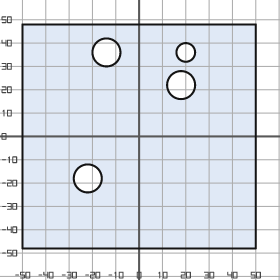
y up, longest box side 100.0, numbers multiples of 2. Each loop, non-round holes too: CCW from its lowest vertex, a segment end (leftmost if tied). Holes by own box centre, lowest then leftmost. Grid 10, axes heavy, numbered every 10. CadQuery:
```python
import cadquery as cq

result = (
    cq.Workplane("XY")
    .moveTo(-50.0, -48.0)
    .lineTo(50.0, -48.0)
    .lineTo(50.0, 48.0)
    .lineTo(-50.0, 48.0)
    .close()
    .moveTo(-22.0, -18.0)
    .circle(6.0)
    .moveTo(18.0, 22.0)
    .circle(6.0)
    .moveTo(-14.0, 36.0)
    .circle(6.0)
    .moveTo(20.0, 36.0)
    .circle(4.0)
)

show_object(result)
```